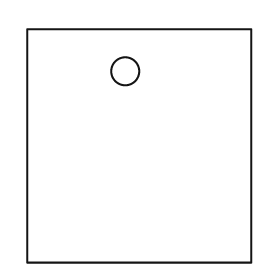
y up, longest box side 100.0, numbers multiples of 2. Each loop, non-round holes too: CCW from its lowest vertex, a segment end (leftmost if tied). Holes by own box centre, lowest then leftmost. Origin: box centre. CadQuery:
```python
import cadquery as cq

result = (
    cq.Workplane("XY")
    .moveTo(-48.0, -50.0)
    .lineTo(48.0, -50.0)
    .lineTo(48.0, 50.0)
    .lineTo(-48.0, 50.0)
    .close()
    .moveTo(-6.0, 32.0)
    .circle(6.0)
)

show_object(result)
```